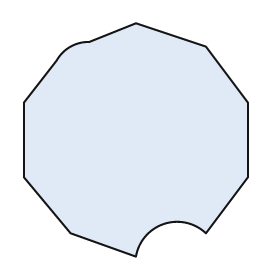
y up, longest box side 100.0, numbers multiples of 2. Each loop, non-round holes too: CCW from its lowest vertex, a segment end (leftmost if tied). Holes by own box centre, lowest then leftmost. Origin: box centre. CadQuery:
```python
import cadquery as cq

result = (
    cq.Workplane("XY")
    .moveTo(0.0, -50.0)
    .threePointArc((12.0, -36.0), (30.0, -40.0))
    .lineTo(48.0, -16.0)
    .lineTo(48.0, 16.0)
    .lineTo(30.0, 40.0)
    .lineTo(0.0, 50.0)
    .lineTo(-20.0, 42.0)
    .threePointArc((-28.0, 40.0), (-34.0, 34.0))
    .lineTo(-48.0, 16.0)
    .lineTo(-48.0, -16.0)
    .lineTo(-28.0, -40.0)
    .close()
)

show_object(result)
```